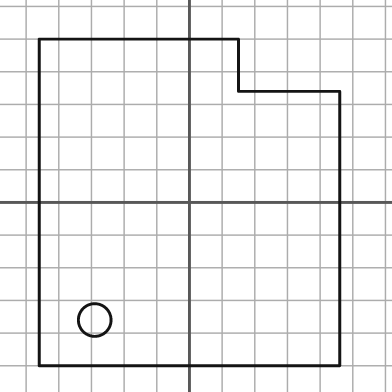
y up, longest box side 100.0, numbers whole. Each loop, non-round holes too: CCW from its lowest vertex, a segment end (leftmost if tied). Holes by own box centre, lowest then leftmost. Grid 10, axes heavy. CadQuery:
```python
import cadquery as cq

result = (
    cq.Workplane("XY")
    .moveTo(-46.0, -50.0)
    .lineTo(46.0, -50.0)
    .lineTo(46.0, 34.0)
    .lineTo(15.0, 34.0)
    .lineTo(15.0, 50.0)
    .lineTo(-46.0, 50.0)
    .close()
    .moveTo(-29.0, -36.0)
    .circle(5.0)
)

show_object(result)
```